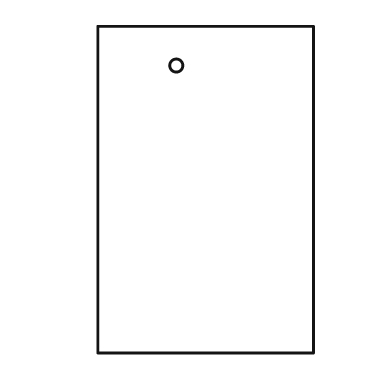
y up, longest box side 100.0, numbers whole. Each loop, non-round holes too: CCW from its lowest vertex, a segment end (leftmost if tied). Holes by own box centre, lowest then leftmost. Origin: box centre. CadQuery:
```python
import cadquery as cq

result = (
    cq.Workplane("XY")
    .moveTo(-33.0, -50.0)
    .lineTo(33.0, -50.0)
    .lineTo(33.0, 50.0)
    .lineTo(-33.0, 50.0)
    .close()
    .moveTo(-9.0, 38.0)
    .circle(2.0)
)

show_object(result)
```